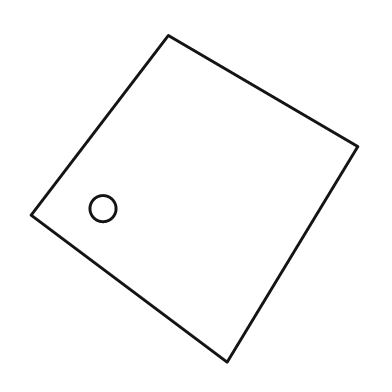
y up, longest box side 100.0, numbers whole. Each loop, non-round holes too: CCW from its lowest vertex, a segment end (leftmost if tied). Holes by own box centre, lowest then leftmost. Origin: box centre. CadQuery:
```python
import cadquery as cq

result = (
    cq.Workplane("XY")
    .moveTo(10.0, -50.0)
    .lineTo(50.0, 16.0)
    .lineTo(-8.0, 50.0)
    .lineTo(-50.0, -5.0)
    .close()
    .moveTo(-28.0, -3.0)
    .circle(4.0)
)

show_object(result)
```